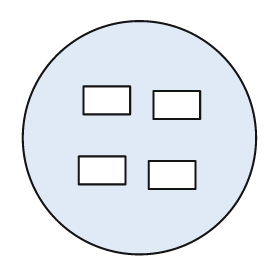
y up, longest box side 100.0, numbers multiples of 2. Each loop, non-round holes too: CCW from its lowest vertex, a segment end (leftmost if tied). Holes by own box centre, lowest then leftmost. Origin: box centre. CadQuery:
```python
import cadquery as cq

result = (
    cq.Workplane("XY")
    .moveTo(0.0, 0.0)
    .circle(50.0)
    .moveTo(4.0, -22.0)
    .lineTo(24.0, -22.0)
    .lineTo(24.0, -10.0)
    .lineTo(4.0, -10.0)
    .close()
    .moveTo(-26.0, -20.0)
    .lineTo(-6.0, -20.0)
    .lineTo(-6.0, -8.0)
    .lineTo(-26.0, -8.0)
    .close()
    .moveTo(6.0, 8.0)
    .lineTo(26.0, 8.0)
    .lineTo(26.0, 20.0)
    .lineTo(6.0, 20.0)
    .close()
    .moveTo(-24.0, 10.0)
    .lineTo(-4.0, 10.0)
    .lineTo(-4.0, 22.0)
    .lineTo(-24.0, 22.0)
    .close()
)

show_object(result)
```